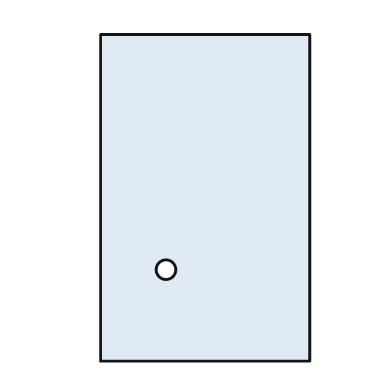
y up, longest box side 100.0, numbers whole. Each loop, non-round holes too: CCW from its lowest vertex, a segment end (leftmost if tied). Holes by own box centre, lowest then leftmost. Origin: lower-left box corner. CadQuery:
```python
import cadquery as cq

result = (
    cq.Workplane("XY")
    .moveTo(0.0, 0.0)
    .lineTo(64.0, 0.0)
    .lineTo(64.0, 100.0)
    .lineTo(0.0, 100.0)
    .close()
    .moveTo(20.0, 28.0)
    .circle(3.0)
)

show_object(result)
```